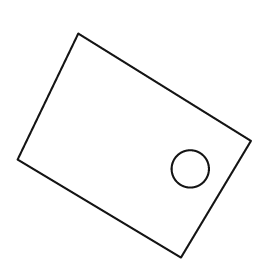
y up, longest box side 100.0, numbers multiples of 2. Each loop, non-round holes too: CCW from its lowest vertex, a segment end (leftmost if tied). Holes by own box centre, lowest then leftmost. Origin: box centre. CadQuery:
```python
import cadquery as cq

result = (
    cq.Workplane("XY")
    .moveTo(20.0, -48.0)
    .lineTo(50.0, 2.0)
    .lineTo(-24.0, 48.0)
    .lineTo(-50.0, -6.0)
    .close()
    .moveTo(24.0, -10.0)
    .circle(8.0)
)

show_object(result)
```